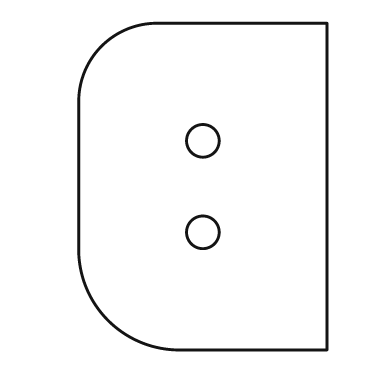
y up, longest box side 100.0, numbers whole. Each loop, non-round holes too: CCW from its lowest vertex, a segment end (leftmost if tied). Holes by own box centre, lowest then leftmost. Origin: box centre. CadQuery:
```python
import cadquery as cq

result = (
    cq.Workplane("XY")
    .moveTo(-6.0, -50.0)
    .lineTo(38.0, -50.0)
    .lineTo(38.0, 50.0)
    .lineTo(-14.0, 50.0)
    .threePointArc((-31.0, 43.0), (-38.0, 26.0))
    .lineTo(-38.0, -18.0)
    .threePointArc((-29.0, -41.0), (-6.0, -50.0))
    .close()
    .moveTo(0.0, -14.0)
    .circle(5.0)
    .moveTo(0.0, 14.0)
    .circle(5.0)
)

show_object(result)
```